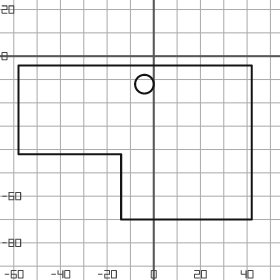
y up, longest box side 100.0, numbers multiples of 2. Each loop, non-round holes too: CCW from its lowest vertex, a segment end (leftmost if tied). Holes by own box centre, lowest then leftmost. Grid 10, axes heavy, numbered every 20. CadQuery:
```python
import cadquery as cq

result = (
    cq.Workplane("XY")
    .moveTo(-14.0, -70.0)
    .lineTo(42.0, -70.0)
    .lineTo(42.0, -4.0)
    .lineTo(-58.0, -4.0)
    .lineTo(-58.0, -42.0)
    .lineTo(-14.0, -42.0)
    .close()
    .moveTo(-4.0, -12.0)
    .circle(4.0)
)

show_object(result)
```